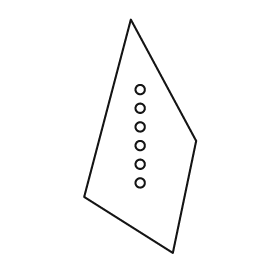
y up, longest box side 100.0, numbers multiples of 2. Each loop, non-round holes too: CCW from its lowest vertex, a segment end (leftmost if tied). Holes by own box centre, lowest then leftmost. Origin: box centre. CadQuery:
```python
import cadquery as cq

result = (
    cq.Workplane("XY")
    .moveTo(14.0, -50.0)
    .lineTo(24.0, -2.0)
    .lineTo(-4.0, 50.0)
    .lineTo(-24.0, -26.0)
    .close()
    .moveTo(0.0, -20.0)
    .circle(2.0)
    .moveTo(0.0, -12.0)
    .circle(2.0)
    .moveTo(0.0, -4.0)
    .circle(2.0)
    .moveTo(0.0, 4.0)
    .circle(2.0)
    .moveTo(0.0, 12.0)
    .circle(2.0)
    .moveTo(0.0, 20.0)
    .circle(2.0)
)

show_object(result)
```